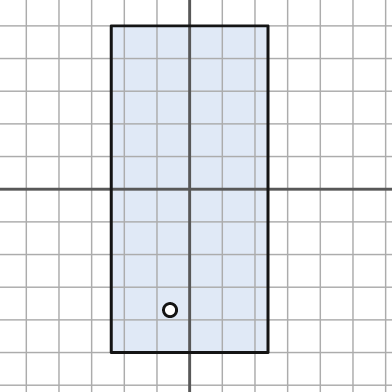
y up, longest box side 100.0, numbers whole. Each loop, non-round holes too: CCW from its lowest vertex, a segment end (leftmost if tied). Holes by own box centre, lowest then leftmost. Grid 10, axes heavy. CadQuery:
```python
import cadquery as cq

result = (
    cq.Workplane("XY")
    .moveTo(-24.0, -50.0)
    .lineTo(24.0, -50.0)
    .lineTo(24.0, 50.0)
    .lineTo(-24.0, 50.0)
    .close()
    .moveTo(-6.0, -37.0)
    .circle(2.0)
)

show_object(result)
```